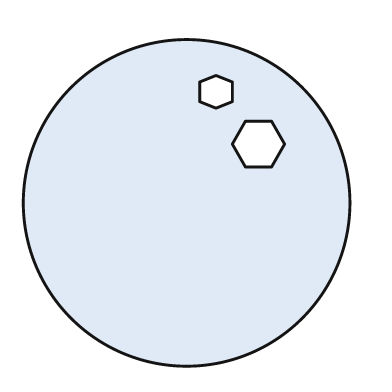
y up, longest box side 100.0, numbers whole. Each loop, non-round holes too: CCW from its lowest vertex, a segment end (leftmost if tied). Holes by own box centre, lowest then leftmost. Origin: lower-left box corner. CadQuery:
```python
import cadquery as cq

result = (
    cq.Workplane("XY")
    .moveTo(50.0, 50.0)
    .circle(50.0)
    .moveTo(68.0, 61.0)
    .lineTo(76.0, 61.0)
    .lineTo(80.0, 68.0)
    .lineTo(76.0, 75.0)
    .lineTo(68.0, 75.0)
    .lineTo(64.0, 68.0)
    .close()
    .moveTo(59.0, 79.0)
    .lineTo(64.0, 81.0)
    .lineTo(64.0, 87.0)
    .lineTo(59.0, 89.0)
    .lineTo(54.0, 87.0)
    .lineTo(54.0, 81.0)
    .close()
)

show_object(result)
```